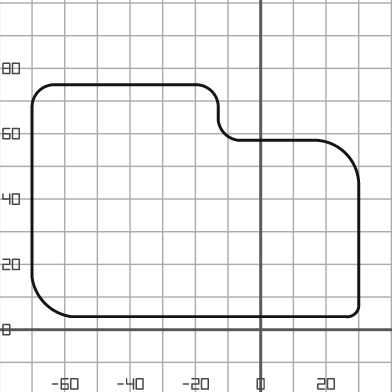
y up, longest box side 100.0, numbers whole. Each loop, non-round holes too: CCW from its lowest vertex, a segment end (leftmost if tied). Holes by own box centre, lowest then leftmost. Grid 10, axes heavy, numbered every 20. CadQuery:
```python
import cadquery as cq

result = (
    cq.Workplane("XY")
    .moveTo(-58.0, 4.0)
    .lineTo(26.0, 4.0)
    .threePointArc((29.0, 5.0), (30.0, 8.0))
    .lineTo(30.0, 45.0)
    .threePointArc((26.0, 54.0), (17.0, 58.0))
    .lineTo(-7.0, 58.0)
    .threePointArc((-11.0, 60.0), (-13.0, 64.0))
    .lineTo(-13.0, 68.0)
    .threePointArc((-15.0, 73.0), (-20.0, 75.0))
    .lineTo(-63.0, 75.0)
    .threePointArc((-68.0, 73.0), (-70.0, 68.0))
    .lineTo(-70.0, 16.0)
    .threePointArc((-66.0, 8.0), (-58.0, 4.0))
    .close()
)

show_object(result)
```